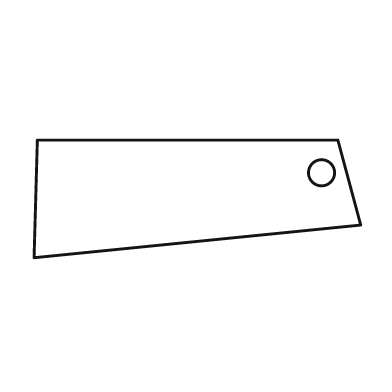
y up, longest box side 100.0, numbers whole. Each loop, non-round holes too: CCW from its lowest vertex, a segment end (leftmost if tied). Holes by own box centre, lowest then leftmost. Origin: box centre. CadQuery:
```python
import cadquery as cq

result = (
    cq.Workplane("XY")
    .moveTo(-50.0, -18.0)
    .lineTo(50.0, -8.0)
    .lineTo(43.0, 18.0)
    .lineTo(-49.0, 18.0)
    .close()
    .moveTo(38.0, 8.0)
    .circle(4.0)
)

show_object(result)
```